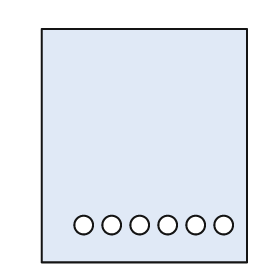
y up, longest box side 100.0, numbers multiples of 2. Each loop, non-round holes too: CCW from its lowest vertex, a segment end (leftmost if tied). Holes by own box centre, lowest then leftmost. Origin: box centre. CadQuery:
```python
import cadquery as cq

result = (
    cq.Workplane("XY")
    .moveTo(-44.0, -50.0)
    .lineTo(44.0, -50.0)
    .lineTo(44.0, 50.0)
    .lineTo(-44.0, 50.0)
    .close()
    .moveTo(-26.0, -34.0)
    .circle(4.0)
    .moveTo(-14.0, -34.0)
    .circle(4.0)
    .moveTo(-2.0, -34.0)
    .circle(4.0)
    .moveTo(10.0, -34.0)
    .circle(4.0)
    .moveTo(22.0, -34.0)
    .circle(4.0)
    .moveTo(34.0, -34.0)
    .circle(4.0)
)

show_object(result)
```